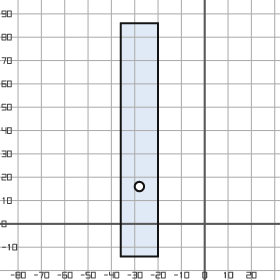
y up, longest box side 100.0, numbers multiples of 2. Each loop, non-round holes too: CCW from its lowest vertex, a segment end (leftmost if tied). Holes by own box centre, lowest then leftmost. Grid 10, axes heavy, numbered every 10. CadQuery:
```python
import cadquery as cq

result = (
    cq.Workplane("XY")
    .moveTo(-36.0, -14.0)
    .lineTo(-20.0, -14.0)
    .lineTo(-20.0, 86.0)
    .lineTo(-36.0, 86.0)
    .close()
    .moveTo(-28.0, 16.0)
    .circle(2.0)
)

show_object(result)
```